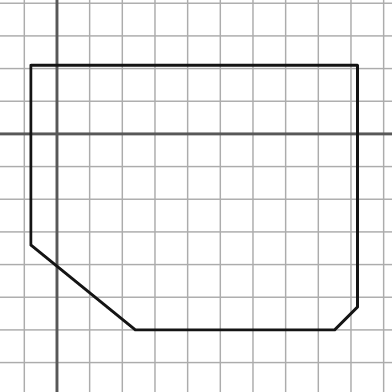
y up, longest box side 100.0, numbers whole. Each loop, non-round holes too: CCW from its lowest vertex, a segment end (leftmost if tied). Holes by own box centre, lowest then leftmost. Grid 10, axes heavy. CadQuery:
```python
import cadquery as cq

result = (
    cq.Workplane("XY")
    .moveTo(24.0, -60.0)
    .lineTo(85.0, -60.0)
    .lineTo(92.0, -53.0)
    .lineTo(92.0, 21.0)
    .lineTo(-8.0, 21.0)
    .lineTo(-8.0, -34.0)
    .close()
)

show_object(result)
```